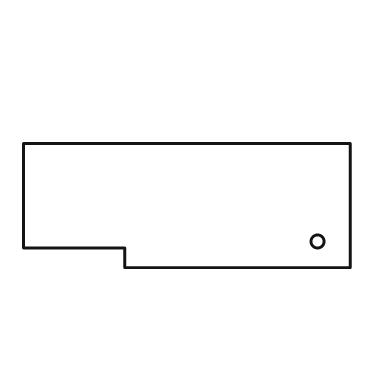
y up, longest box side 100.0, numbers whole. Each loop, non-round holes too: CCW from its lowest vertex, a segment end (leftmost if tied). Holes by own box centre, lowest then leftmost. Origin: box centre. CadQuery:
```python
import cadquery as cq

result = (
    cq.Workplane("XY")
    .moveTo(-19.0, -19.0)
    .lineTo(50.0, -19.0)
    .lineTo(50.0, 19.0)
    .lineTo(-50.0, 19.0)
    .lineTo(-50.0, -13.0)
    .lineTo(-19.0, -13.0)
    .close()
    .moveTo(40.0, -11.0)
    .circle(2.0)
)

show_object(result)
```